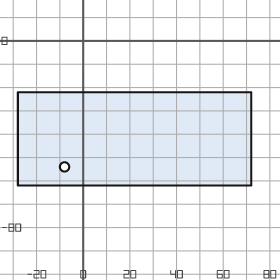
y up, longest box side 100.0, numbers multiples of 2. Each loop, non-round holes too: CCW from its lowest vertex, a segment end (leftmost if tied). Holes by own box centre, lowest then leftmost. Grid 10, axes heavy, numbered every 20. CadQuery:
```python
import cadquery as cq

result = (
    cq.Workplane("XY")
    .moveTo(-28.0, -62.0)
    .lineTo(72.0, -62.0)
    .lineTo(72.0, -22.0)
    .lineTo(-28.0, -22.0)
    .close()
    .moveTo(-8.0, -54.0)
    .circle(2.0)
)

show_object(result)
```